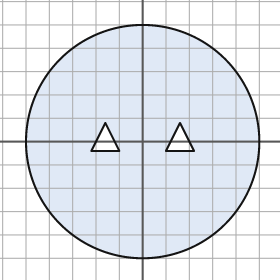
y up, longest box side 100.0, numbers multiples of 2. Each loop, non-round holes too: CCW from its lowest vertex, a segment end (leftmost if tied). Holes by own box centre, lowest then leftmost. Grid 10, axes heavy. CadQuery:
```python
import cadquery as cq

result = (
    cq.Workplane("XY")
    .moveTo(0.0, 0.0)
    .circle(50.0)
    .moveTo(-22.0, -4.0)
    .lineTo(-10.0, -4.0)
    .lineTo(-16.0, 8.0)
    .close()
    .moveTo(10.0, -4.0)
    .lineTo(22.0, -4.0)
    .lineTo(16.0, 8.0)
    .close()
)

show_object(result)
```